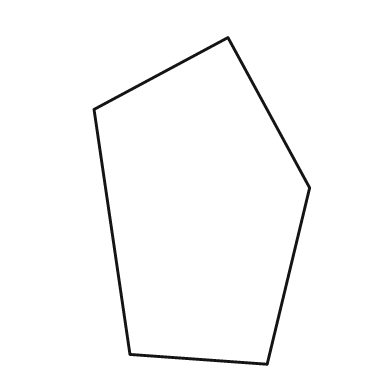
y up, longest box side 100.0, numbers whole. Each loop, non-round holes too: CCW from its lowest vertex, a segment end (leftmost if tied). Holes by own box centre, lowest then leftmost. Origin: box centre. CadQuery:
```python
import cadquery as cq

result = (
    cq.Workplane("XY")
    .moveTo(20.0, -50.0)
    .lineTo(33.0, 4.0)
    .lineTo(8.0, 50.0)
    .lineTo(-33.0, 28.0)
    .lineTo(-22.0, -47.0)
    .close()
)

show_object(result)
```